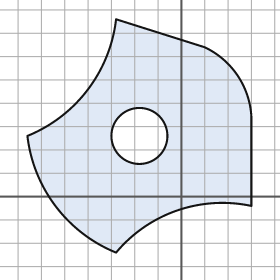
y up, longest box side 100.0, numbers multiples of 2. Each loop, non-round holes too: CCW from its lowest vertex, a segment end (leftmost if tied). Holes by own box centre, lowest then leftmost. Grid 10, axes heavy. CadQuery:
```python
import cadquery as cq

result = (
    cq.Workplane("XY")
    .moveTo(-28.0, -24.0)
    .threePointArc((-2.0, -6.0), (30.0, -4.0))
    .lineTo(30.0, 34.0)
    .threePointArc((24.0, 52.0), (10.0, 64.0))
    .lineTo(-28.0, 76.0)
    .threePointArc((-40.0, 46.0), (-66.0, 26.0))
    .threePointArc((-54.0, -4.0), (-28.0, -24.0))
    .close()
    .moveTo(-18.0, 26.0)
    .circle(12.0)
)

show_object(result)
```